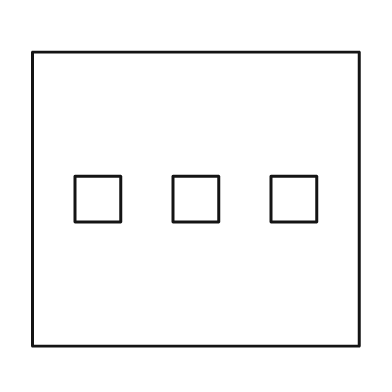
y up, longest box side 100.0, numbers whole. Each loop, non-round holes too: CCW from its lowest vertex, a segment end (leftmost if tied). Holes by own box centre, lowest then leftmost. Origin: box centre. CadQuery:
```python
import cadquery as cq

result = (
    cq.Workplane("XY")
    .moveTo(-50.0, -45.0)
    .lineTo(50.0, -45.0)
    .lineTo(50.0, 45.0)
    .lineTo(-50.0, 45.0)
    .close()
    .moveTo(-37.0, -7.0)
    .lineTo(-23.0, -7.0)
    .lineTo(-23.0, 7.0)
    .lineTo(-37.0, 7.0)
    .close()
    .moveTo(-7.0, -7.0)
    .lineTo(7.0, -7.0)
    .lineTo(7.0, 7.0)
    .lineTo(-7.0, 7.0)
    .close()
    .moveTo(23.0, -7.0)
    .lineTo(37.0, -7.0)
    .lineTo(37.0, 7.0)
    .lineTo(23.0, 7.0)
    .close()
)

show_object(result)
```